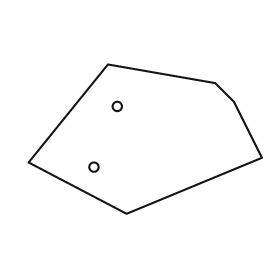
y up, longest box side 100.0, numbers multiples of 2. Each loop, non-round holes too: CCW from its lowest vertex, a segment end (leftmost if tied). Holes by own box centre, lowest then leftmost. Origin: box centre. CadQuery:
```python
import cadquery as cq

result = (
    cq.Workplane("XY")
    .moveTo(-8.0, -32.0)
    .lineTo(50.0, -8.0)
    .lineTo(38.0, 16.0)
    .lineTo(30.0, 24.0)
    .lineTo(-16.0, 32.0)
    .lineTo(-50.0, -10.0)
    .close()
    .moveTo(-22.0, -12.0)
    .circle(2.0)
    .moveTo(-12.0, 14.0)
    .circle(2.0)
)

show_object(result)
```